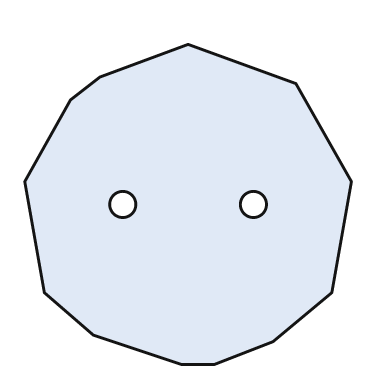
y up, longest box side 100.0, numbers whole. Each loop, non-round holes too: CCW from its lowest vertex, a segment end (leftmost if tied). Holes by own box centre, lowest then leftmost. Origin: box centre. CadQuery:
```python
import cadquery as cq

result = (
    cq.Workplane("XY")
    .moveTo(-2.0, -49.0)
    .lineTo(8.0, -49.0)
    .lineTo(26.0, -42.0)
    .lineTo(44.0, -27.0)
    .lineTo(50.0, 7.0)
    .lineTo(33.0, 37.0)
    .lineTo(0.0, 49.0)
    .lineTo(-27.0, 39.0)
    .lineTo(-36.0, 32.0)
    .lineTo(-50.0, 7.0)
    .lineTo(-44.0, -27.0)
    .lineTo(-29.0, -40.0)
    .close()
    .moveTo(-20.0, 0.0)
    .circle(4.0)
    .moveTo(20.0, 0.0)
    .circle(4.0)
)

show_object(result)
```